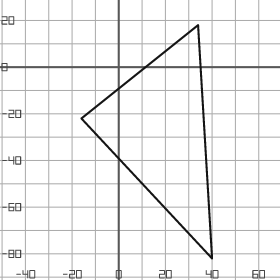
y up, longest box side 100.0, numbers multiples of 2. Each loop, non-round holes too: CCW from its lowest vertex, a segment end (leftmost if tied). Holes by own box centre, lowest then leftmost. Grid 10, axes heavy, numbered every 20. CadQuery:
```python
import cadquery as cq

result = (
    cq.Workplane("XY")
    .moveTo(40.0, -82.0)
    .lineTo(34.0, 18.0)
    .lineTo(-16.0, -22.0)
    .close()
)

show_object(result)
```